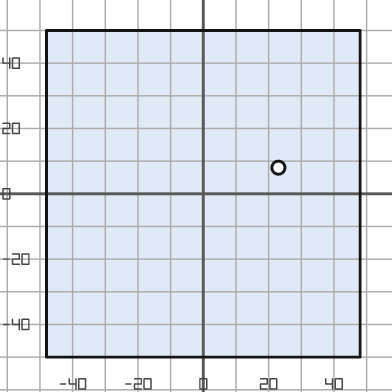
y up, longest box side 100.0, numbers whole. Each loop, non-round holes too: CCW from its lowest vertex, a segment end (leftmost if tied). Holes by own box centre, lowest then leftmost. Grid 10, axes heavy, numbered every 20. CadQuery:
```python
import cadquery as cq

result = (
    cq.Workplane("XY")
    .moveTo(-48.0, -50.0)
    .lineTo(48.0, -50.0)
    .lineTo(48.0, 50.0)
    .lineTo(-48.0, 50.0)
    .close()
    .moveTo(23.0, 8.0)
    .circle(2.0)
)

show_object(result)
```